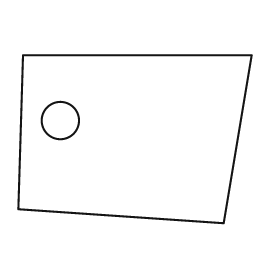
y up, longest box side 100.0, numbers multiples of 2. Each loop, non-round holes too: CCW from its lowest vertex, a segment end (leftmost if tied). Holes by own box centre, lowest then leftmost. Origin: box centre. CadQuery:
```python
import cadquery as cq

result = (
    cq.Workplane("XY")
    .moveTo(38.0, -36.0)
    .lineTo(50.0, 36.0)
    .lineTo(-48.0, 36.0)
    .lineTo(-50.0, -30.0)
    .close()
    .moveTo(-32.0, 8.0)
    .circle(8.0)
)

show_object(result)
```